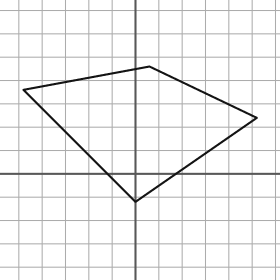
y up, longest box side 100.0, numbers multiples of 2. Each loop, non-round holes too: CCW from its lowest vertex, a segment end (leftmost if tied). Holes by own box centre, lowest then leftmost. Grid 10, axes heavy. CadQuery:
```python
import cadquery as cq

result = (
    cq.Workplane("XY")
    .moveTo(0.0, -12.0)
    .lineTo(52.0, 24.0)
    .lineTo(6.0, 46.0)
    .lineTo(-48.0, 36.0)
    .close()
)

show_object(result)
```